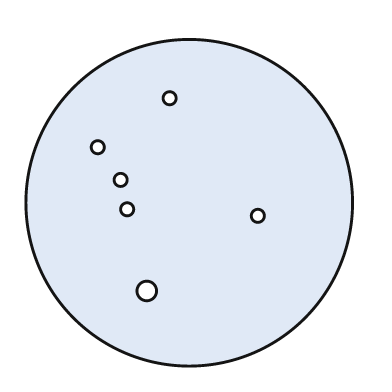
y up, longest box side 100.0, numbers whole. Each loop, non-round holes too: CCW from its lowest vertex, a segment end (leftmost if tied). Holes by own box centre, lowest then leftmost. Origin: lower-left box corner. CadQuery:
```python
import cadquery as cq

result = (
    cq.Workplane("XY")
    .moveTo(50.0, 50.0)
    .circle(50.0)
    .moveTo(37.0, 23.0)
    .circle(3.0)
    .moveTo(71.0, 46.0)
    .circle(2.0)
    .moveTo(31.0, 48.0)
    .circle(2.0)
    .moveTo(29.0, 57.0)
    .circle(2.0)
    .moveTo(22.0, 67.0)
    .circle(2.0)
    .moveTo(44.0, 82.0)
    .circle(2.0)
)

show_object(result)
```